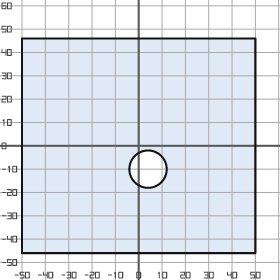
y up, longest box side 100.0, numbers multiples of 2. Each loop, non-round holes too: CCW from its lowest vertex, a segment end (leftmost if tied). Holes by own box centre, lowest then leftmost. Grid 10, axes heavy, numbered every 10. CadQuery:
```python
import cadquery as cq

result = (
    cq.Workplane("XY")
    .moveTo(-50.0, -46.0)
    .lineTo(50.0, -46.0)
    .lineTo(50.0, 46.0)
    .lineTo(-50.0, 46.0)
    .close()
    .moveTo(4.0, -10.0)
    .circle(8.0)
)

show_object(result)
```